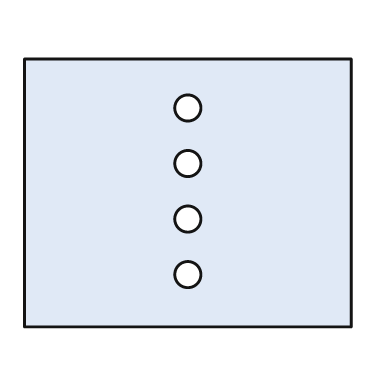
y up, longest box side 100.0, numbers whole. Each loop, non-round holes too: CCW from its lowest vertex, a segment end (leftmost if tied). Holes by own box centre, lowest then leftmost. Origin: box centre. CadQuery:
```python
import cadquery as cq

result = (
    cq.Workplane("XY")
    .moveTo(-50.0, -41.0)
    .lineTo(50.0, -41.0)
    .lineTo(50.0, 41.0)
    .lineTo(-50.0, 41.0)
    .close()
    .moveTo(0.0, -25.0)
    .circle(4.0)
    .moveTo(0.0, -8.0)
    .circle(4.0)
    .moveTo(0.0, 9.0)
    .circle(4.0)
    .moveTo(0.0, 26.0)
    .circle(4.0)
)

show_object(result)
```